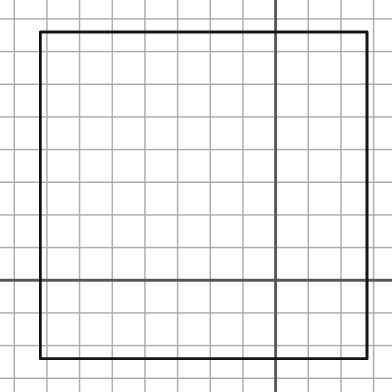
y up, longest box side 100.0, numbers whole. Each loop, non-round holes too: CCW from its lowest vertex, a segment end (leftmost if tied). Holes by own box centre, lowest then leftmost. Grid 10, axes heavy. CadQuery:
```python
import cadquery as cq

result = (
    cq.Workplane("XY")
    .moveTo(-72.0, -24.0)
    .lineTo(28.0, -24.0)
    .lineTo(28.0, 76.0)
    .lineTo(-72.0, 76.0)
    .close()
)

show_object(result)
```